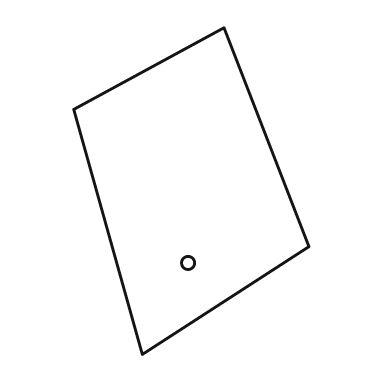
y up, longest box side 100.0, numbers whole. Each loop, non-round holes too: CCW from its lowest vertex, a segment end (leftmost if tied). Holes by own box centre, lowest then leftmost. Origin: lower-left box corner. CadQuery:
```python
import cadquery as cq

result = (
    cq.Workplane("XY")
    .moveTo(21.0, 0.0)
    .lineTo(72.0, 33.0)
    .lineTo(46.0, 100.0)
    .lineTo(0.0, 75.0)
    .close()
    .moveTo(35.0, 28.0)
    .circle(2.0)
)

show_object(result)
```